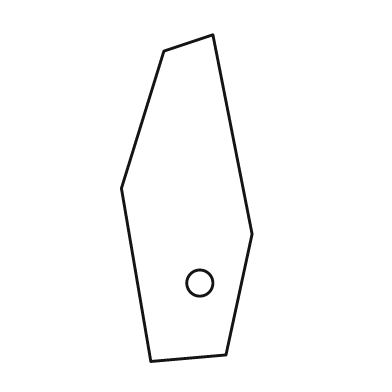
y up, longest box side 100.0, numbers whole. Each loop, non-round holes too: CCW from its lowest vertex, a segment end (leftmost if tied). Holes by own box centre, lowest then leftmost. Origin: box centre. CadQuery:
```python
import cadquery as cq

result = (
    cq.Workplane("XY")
    .moveTo(-11.0, -50.0)
    .lineTo(12.0, -48.0)
    .lineTo(20.0, -11.0)
    .lineTo(8.0, 50.0)
    .lineTo(-7.0, 45.0)
    .lineTo(-20.0, 3.0)
    .close()
    .moveTo(4.0, -26.0)
    .circle(4.0)
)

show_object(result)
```